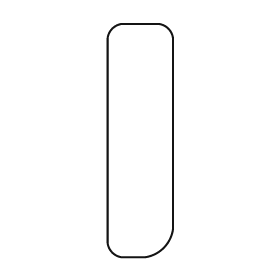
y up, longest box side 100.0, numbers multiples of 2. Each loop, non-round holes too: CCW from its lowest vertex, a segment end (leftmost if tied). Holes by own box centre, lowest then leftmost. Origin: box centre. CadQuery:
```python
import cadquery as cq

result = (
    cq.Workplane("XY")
    .moveTo(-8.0, -50.0)
    .lineTo(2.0, -50.0)
    .threePointArc((10.0, -46.0), (14.0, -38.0))
    .lineTo(14.0, 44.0)
    .threePointArc((12.0, 48.0), (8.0, 50.0))
    .lineTo(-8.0, 50.0)
    .threePointArc((-12.0, 48.0), (-14.0, 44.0))
    .lineTo(-14.0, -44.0)
    .threePointArc((-12.0, -48.0), (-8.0, -50.0))
    .close()
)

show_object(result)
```